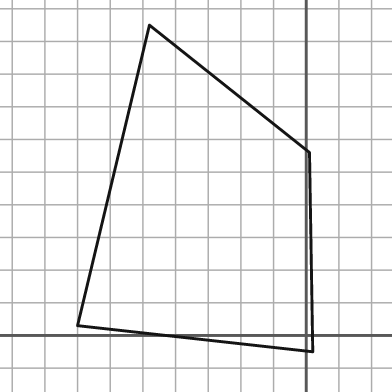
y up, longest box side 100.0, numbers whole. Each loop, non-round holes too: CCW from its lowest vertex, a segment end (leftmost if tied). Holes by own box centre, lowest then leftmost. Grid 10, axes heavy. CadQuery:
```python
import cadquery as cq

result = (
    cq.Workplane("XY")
    .moveTo(2.0, -5.0)
    .lineTo(1.0, 56.0)
    .lineTo(-48.0, 95.0)
    .lineTo(-70.0, 3.0)
    .close()
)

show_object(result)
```